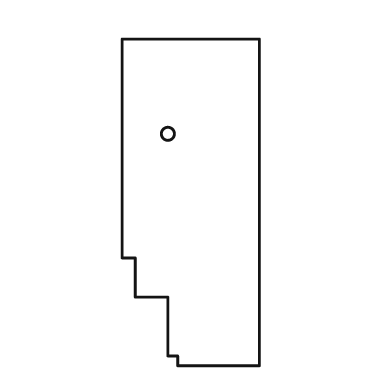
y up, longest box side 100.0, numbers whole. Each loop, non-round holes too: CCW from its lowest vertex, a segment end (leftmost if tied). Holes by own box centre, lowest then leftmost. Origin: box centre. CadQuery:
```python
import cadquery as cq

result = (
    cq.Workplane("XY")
    .moveTo(-4.0, -50.0)
    .lineTo(21.0, -50.0)
    .lineTo(21.0, 50.0)
    .lineTo(-21.0, 50.0)
    .lineTo(-21.0, -17.0)
    .lineTo(-17.0, -17.0)
    .lineTo(-17.0, -29.0)
    .lineTo(-7.0, -29.0)
    .lineTo(-7.0, -47.0)
    .lineTo(-4.0, -47.0)
    .close()
    .moveTo(-7.0, 21.0)
    .circle(2.0)
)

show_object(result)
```